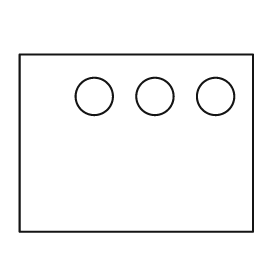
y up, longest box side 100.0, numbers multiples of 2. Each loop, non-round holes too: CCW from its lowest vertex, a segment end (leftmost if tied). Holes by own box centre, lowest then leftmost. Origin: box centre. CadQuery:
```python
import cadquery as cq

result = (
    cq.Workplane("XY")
    .moveTo(-50.0, -38.0)
    .lineTo(50.0, -38.0)
    .lineTo(50.0, 38.0)
    .lineTo(-50.0, 38.0)
    .close()
    .moveTo(-18.0, 20.0)
    .circle(8.0)
    .moveTo(8.0, 20.0)
    .circle(8.0)
    .moveTo(34.0, 20.0)
    .circle(8.0)
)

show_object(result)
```